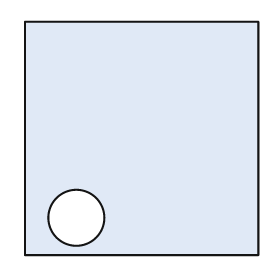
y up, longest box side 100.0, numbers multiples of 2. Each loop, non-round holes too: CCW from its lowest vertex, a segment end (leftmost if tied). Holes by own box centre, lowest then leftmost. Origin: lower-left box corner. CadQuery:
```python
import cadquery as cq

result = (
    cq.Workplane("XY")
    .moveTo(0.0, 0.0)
    .lineTo(100.0, 0.0)
    .lineTo(100.0, 100.0)
    .lineTo(0.0, 100.0)
    .close()
    .moveTo(22.0, 16.0)
    .circle(12.0)
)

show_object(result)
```